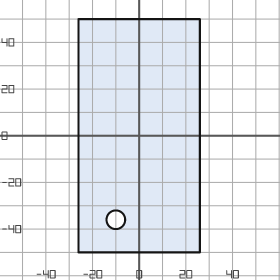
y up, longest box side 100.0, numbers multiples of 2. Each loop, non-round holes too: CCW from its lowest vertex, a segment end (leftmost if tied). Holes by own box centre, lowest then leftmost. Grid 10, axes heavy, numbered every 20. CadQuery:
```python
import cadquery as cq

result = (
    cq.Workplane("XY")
    .moveTo(-26.0, -50.0)
    .lineTo(26.0, -50.0)
    .lineTo(26.0, 50.0)
    .lineTo(-26.0, 50.0)
    .close()
    .moveTo(-10.0, -36.0)
    .circle(4.0)
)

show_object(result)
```